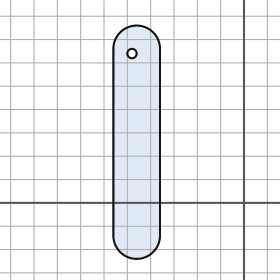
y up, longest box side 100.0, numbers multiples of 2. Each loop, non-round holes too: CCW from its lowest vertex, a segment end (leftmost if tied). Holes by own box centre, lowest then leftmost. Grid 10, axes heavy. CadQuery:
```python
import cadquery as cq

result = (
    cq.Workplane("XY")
    .moveTo(-56.0, -14.0)
    .threePointArc((-46.0, -24.0), (-36.0, -14.0))
    .lineTo(-36.0, 66.0)
    .threePointArc((-46.0, 76.0), (-56.0, 66.0))
    .close()
    .moveTo(-48.0, 64.0)
    .circle(2.0)
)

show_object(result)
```